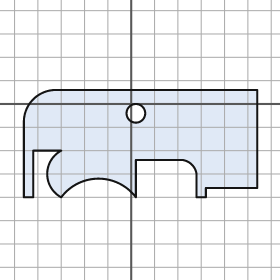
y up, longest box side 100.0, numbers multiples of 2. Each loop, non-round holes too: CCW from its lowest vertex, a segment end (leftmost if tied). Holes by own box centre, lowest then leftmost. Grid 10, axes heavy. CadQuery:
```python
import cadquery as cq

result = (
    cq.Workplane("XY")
    .moveTo(-46.0, -40.0)
    .lineTo(-42.0, -40.0)
    .lineTo(-42.0, -20.0)
    .lineTo(-30.0, -20.0)
    .threePointArc((-36.0, -30.0), (-30.0, -40.0))
    .threePointArc((-14.0, -32.0), (2.0, -40.0))
    .lineTo(2.0, -24.0)
    .lineTo(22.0, -24.0)
    .threePointArc((26.0, -26.0), (28.0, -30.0))
    .lineTo(28.0, -40.0)
    .lineTo(32.0, -40.0)
    .lineTo(32.0, -36.0)
    .lineTo(54.0, -36.0)
    .lineTo(54.0, 6.0)
    .lineTo(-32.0, 6.0)
    .threePointArc((-42.0, 2.0), (-46.0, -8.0))
    .close()
    .moveTo(2.0, -4.0)
    .circle(4.0)
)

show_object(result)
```